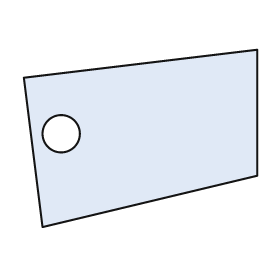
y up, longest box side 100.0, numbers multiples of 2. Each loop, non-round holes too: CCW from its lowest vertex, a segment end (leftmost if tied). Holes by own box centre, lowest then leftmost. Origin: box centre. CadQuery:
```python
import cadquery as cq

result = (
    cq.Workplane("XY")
    .moveTo(-42.0, -38.0)
    .lineTo(50.0, -16.0)
    .lineTo(50.0, 38.0)
    .lineTo(-50.0, 26.0)
    .close()
    .moveTo(-34.0, 2.0)
    .circle(8.0)
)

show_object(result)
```